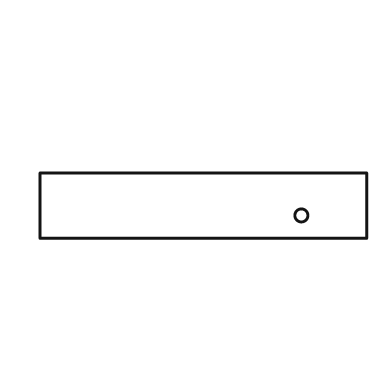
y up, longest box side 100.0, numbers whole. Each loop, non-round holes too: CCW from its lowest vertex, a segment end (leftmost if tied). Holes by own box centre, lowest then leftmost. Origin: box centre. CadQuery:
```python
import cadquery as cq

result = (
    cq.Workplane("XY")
    .moveTo(-50.0, -10.0)
    .lineTo(50.0, -10.0)
    .lineTo(50.0, 10.0)
    .lineTo(-50.0, 10.0)
    .close()
    .moveTo(30.0, -3.0)
    .circle(2.0)
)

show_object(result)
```